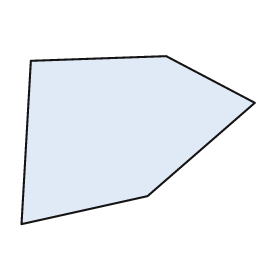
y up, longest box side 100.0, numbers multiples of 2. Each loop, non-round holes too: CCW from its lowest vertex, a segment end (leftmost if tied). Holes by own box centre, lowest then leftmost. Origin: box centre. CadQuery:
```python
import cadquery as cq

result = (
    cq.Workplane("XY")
    .moveTo(-50.0, -36.0)
    .lineTo(4.0, -24.0)
    .lineTo(50.0, 16.0)
    .lineTo(12.0, 36.0)
    .lineTo(-46.0, 34.0)
    .close()
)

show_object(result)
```